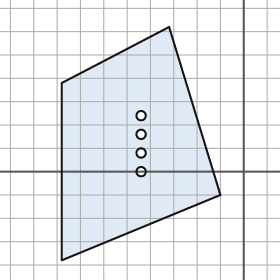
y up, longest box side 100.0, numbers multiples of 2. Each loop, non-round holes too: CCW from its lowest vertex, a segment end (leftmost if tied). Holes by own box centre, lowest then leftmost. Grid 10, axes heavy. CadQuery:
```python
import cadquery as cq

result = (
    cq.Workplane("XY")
    .moveTo(-78.0, -38.0)
    .lineTo(-10.0, -10.0)
    .lineTo(-32.0, 62.0)
    .lineTo(-78.0, 38.0)
    .close()
    .moveTo(-44.0, 0.0)
    .circle(2.0)
    .moveTo(-44.0, 8.0)
    .circle(2.0)
    .moveTo(-44.0, 16.0)
    .circle(2.0)
    .moveTo(-44.0, 24.0)
    .circle(2.0)
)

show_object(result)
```